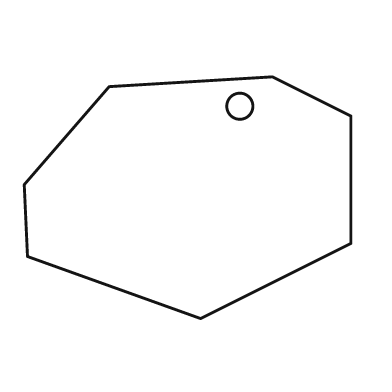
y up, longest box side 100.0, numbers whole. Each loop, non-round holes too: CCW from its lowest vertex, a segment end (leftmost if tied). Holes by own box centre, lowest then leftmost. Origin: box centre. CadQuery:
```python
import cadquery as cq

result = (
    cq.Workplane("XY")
    .moveTo(4.0, -37.0)
    .lineTo(50.0, -14.0)
    .lineTo(50.0, 25.0)
    .lineTo(26.0, 37.0)
    .lineTo(-24.0, 34.0)
    .lineTo(-50.0, 4.0)
    .lineTo(-49.0, -18.0)
    .close()
    .moveTo(16.0, 28.0)
    .circle(4.0)
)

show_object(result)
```